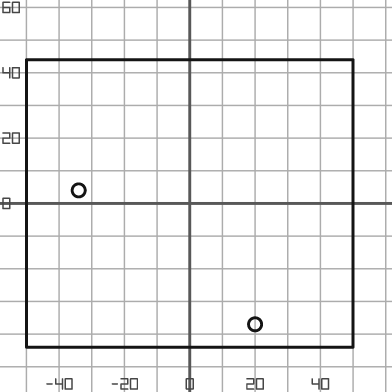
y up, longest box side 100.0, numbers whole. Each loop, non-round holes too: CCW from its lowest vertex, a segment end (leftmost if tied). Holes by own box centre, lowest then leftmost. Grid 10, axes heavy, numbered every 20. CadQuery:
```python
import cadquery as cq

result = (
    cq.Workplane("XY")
    .moveTo(-50.0, -44.0)
    .lineTo(50.0, -44.0)
    .lineTo(50.0, 44.0)
    .lineTo(-50.0, 44.0)
    .close()
    .moveTo(20.0, -37.0)
    .circle(2.0)
    .moveTo(-34.0, 4.0)
    .circle(2.0)
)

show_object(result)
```